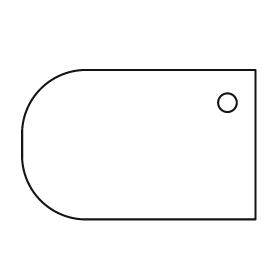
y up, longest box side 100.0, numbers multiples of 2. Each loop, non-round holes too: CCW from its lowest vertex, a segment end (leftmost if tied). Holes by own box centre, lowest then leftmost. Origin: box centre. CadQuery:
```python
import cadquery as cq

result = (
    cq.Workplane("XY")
    .moveTo(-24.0, -32.0)
    .lineTo(50.0, -32.0)
    .lineTo(50.0, 32.0)
    .lineTo(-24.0, 32.0)
    .threePointArc((-42.0, 24.0), (-50.0, 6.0))
    .lineTo(-50.0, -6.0)
    .threePointArc((-42.0, -24.0), (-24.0, -32.0))
    .close()
    .moveTo(38.0, 18.0)
    .circle(4.0)
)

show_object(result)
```